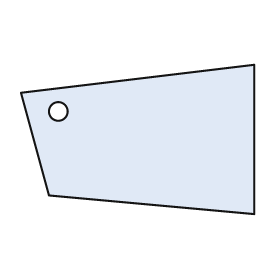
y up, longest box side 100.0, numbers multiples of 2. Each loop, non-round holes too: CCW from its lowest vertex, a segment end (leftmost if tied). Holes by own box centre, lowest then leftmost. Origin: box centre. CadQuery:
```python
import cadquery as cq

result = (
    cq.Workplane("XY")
    .moveTo(50.0, -32.0)
    .lineTo(50.0, 32.0)
    .lineTo(-50.0, 20.0)
    .lineTo(-38.0, -24.0)
    .close()
    .moveTo(-34.0, 12.0)
    .circle(4.0)
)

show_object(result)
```